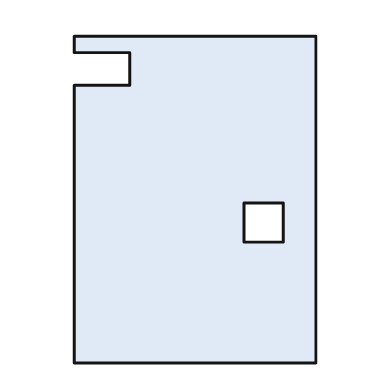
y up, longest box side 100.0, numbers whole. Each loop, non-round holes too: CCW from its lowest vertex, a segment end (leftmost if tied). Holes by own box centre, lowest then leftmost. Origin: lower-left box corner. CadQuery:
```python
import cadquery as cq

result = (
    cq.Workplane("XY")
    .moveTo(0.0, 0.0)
    .lineTo(74.0, 0.0)
    .lineTo(74.0, 100.0)
    .lineTo(0.0, 100.0)
    .lineTo(0.0, 95.0)
    .lineTo(17.0, 95.0)
    .lineTo(17.0, 85.0)
    .lineTo(0.0, 85.0)
    .close()
    .moveTo(52.0, 37.0)
    .lineTo(64.0, 37.0)
    .lineTo(64.0, 49.0)
    .lineTo(52.0, 49.0)
    .close()
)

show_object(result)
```